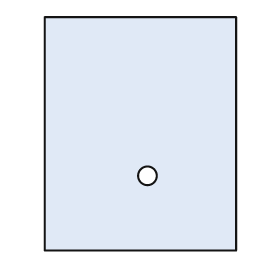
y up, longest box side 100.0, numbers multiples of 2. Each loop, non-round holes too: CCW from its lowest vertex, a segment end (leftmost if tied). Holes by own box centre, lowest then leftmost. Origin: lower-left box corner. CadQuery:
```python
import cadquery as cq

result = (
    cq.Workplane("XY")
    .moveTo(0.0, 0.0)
    .lineTo(82.0, 0.0)
    .lineTo(82.0, 100.0)
    .lineTo(0.0, 100.0)
    .close()
    .moveTo(44.0, 32.0)
    .circle(4.0)
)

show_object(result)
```